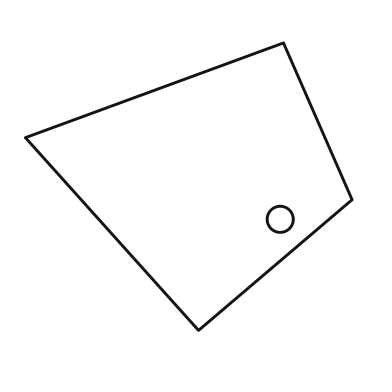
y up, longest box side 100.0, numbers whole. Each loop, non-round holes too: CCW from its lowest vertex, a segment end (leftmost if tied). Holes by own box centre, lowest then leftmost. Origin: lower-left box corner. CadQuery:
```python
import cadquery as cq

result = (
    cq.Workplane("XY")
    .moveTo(53.0, 0.0)
    .lineTo(100.0, 40.0)
    .lineTo(79.0, 88.0)
    .lineTo(0.0, 59.0)
    .close()
    .moveTo(78.0, 34.0)
    .circle(4.0)
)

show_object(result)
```